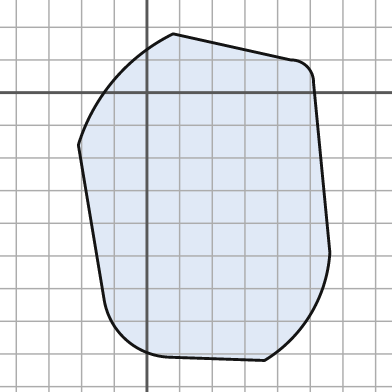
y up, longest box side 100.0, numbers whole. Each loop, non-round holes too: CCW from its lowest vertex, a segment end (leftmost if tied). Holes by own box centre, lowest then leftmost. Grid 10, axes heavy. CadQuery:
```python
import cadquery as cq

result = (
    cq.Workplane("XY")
    .moveTo(36.0, -82.0)
    .threePointArc((50.0, -68.0), (56.0, -49.0))
    .lineTo(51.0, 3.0)
    .threePointArc((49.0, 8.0), (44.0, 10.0))
    .lineTo(8.0, 18.0)
    .threePointArc((-10.0, 4.0), (-21.0, -16.0))
    .lineTo(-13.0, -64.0)
    .threePointArc((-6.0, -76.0), (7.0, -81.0))
    .close()
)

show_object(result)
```